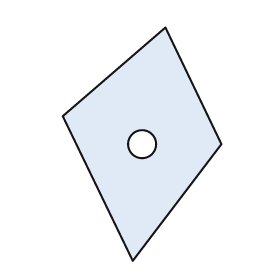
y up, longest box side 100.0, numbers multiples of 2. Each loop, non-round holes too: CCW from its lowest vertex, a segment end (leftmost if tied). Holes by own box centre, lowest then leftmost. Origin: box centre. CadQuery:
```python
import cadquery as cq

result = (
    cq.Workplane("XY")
    .moveTo(-4.0, -50.0)
    .lineTo(34.0, 0.0)
    .lineTo(10.0, 50.0)
    .lineTo(-34.0, 12.0)
    .close()
    .moveTo(0.0, 0.0)
    .circle(6.0)
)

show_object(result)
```